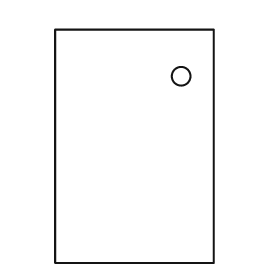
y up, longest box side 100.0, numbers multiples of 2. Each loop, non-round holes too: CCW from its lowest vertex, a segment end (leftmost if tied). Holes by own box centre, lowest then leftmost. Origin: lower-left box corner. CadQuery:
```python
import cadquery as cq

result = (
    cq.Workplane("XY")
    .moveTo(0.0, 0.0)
    .lineTo(68.0, 0.0)
    .lineTo(68.0, 100.0)
    .lineTo(0.0, 100.0)
    .close()
    .moveTo(54.0, 80.0)
    .circle(4.0)
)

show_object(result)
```